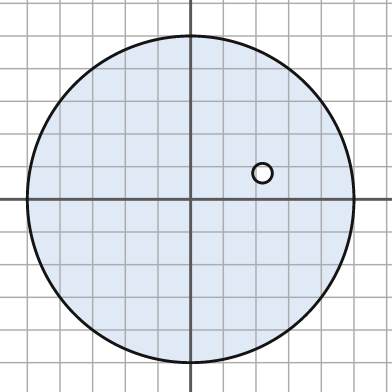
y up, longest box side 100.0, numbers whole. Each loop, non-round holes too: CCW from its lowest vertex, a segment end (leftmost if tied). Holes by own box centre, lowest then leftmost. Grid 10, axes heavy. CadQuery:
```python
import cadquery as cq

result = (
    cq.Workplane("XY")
    .moveTo(0.0, 0.0)
    .circle(50.0)
    .moveTo(22.0, 8.0)
    .circle(3.0)
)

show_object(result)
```